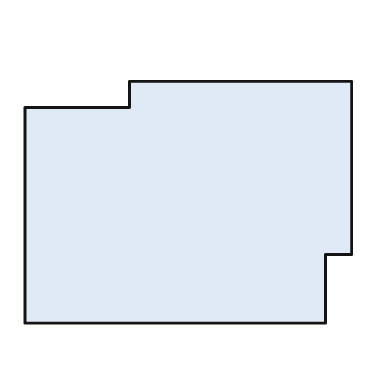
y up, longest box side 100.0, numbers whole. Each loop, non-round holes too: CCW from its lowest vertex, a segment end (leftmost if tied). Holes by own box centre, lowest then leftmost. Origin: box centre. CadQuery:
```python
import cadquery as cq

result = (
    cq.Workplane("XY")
    .moveTo(-50.0, -37.0)
    .lineTo(42.0, -37.0)
    .lineTo(42.0, -16.0)
    .lineTo(50.0, -16.0)
    .lineTo(50.0, 37.0)
    .lineTo(-18.0, 37.0)
    .lineTo(-18.0, 29.0)
    .lineTo(-50.0, 29.0)
    .close()
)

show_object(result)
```